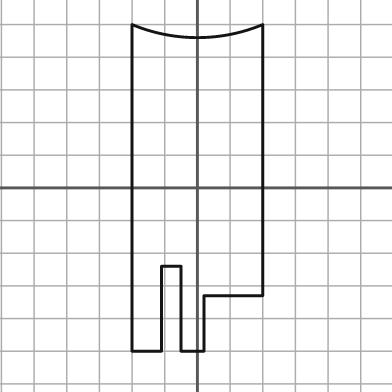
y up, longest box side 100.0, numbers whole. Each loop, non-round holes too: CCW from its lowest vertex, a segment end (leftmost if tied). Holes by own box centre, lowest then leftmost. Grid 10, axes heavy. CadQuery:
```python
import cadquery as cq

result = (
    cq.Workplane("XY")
    .moveTo(-20.0, -50.0)
    .lineTo(-11.0, -50.0)
    .lineTo(-11.0, -24.0)
    .lineTo(-5.0, -24.0)
    .lineTo(-5.0, -50.0)
    .lineTo(2.0, -50.0)
    .lineTo(2.0, -33.0)
    .lineTo(20.0, -33.0)
    .lineTo(20.0, 50.0)
    .threePointArc((0.0, 46.0), (-20.0, 50.0))
    .close()
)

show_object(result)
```